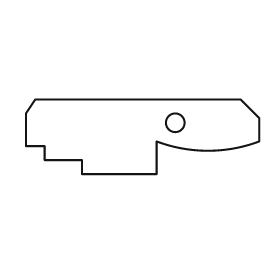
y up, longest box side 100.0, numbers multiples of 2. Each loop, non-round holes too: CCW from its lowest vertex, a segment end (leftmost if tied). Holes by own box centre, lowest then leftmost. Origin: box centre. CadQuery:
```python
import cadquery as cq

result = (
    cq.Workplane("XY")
    .moveTo(-26.0, -16.0)
    .lineTo(6.0, -16.0)
    .lineTo(6.0, -2.0)
    .threePointArc((28.0, -6.0), (50.0, -2.0))
    .lineTo(50.0, 8.0)
    .lineTo(42.0, 16.0)
    .lineTo(-46.0, 16.0)
    .lineTo(-50.0, 10.0)
    .lineTo(-50.0, -4.0)
    .lineTo(-42.0, -4.0)
    .lineTo(-42.0, -10.0)
    .lineTo(-26.0, -10.0)
    .close()
    .moveTo(14.0, 6.0)
    .circle(4.0)
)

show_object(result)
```